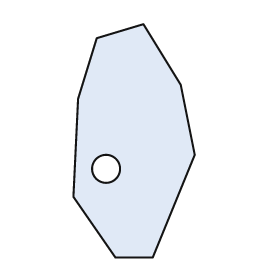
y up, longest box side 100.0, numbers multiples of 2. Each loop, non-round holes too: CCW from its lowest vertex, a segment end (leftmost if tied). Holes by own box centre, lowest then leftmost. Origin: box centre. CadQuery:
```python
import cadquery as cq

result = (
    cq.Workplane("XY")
    .moveTo(-8.0, -50.0)
    .lineTo(8.0, -50.0)
    .lineTo(26.0, -6.0)
    .lineTo(20.0, 24.0)
    .lineTo(4.0, 50.0)
    .lineTo(-16.0, 44.0)
    .lineTo(-24.0, 18.0)
    .lineTo(-26.0, -24.0)
    .close()
    .moveTo(-12.0, -12.0)
    .circle(6.0)
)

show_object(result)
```